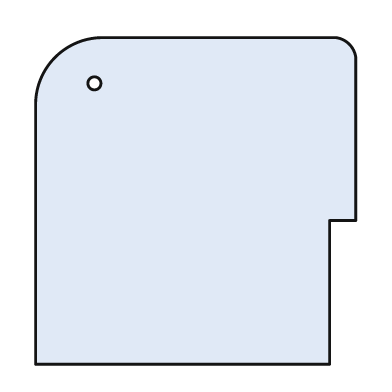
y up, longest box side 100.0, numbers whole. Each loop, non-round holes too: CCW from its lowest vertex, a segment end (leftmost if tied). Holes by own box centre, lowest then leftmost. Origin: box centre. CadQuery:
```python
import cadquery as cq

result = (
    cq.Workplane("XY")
    .moveTo(-49.0, -50.0)
    .lineTo(41.0, -50.0)
    .lineTo(41.0, -6.0)
    .lineTo(49.0, -6.0)
    .lineTo(49.0, 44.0)
    .threePointArc((47.0, 48.0), (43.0, 50.0))
    .lineTo(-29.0, 50.0)
    .threePointArc((-43.0, 44.0), (-49.0, 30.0))
    .close()
    .moveTo(-31.0, 36.0)
    .circle(2.0)
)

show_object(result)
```